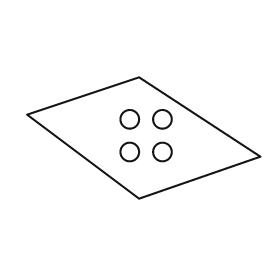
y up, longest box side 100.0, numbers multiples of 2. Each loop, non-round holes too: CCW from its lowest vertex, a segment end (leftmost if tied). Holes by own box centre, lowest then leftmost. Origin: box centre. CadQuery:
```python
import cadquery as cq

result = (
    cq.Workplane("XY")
    .moveTo(-2.0, -26.0)
    .lineTo(50.0, -8.0)
    .lineTo(-2.0, 26.0)
    .lineTo(-50.0, 10.0)
    .close()
    .moveTo(-6.0, -6.0)
    .circle(4.0)
    .moveTo(8.0, -6.0)
    .circle(4.0)
    .moveTo(-6.0, 8.0)
    .circle(4.0)
    .moveTo(8.0, 8.0)
    .circle(4.0)
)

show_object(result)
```